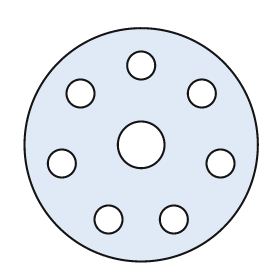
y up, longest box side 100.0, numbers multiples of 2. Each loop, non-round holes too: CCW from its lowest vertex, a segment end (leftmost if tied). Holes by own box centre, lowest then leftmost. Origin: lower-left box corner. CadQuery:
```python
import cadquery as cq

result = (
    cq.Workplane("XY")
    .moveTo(50.0, 50.0)
    .circle(50.0)
    .moveTo(36.0, 18.0)
    .circle(6.0)
    .moveTo(64.0, 18.0)
    .circle(6.0)
    .moveTo(16.0, 42.0)
    .circle(6.0)
    .moveTo(84.0, 42.0)
    .circle(6.0)
    .moveTo(50.0, 50.0)
    .circle(10.0)
    .moveTo(24.0, 72.0)
    .circle(6.0)
    .moveTo(76.0, 72.0)
    .circle(6.0)
    .moveTo(50.0, 84.0)
    .circle(6.0)
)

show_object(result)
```